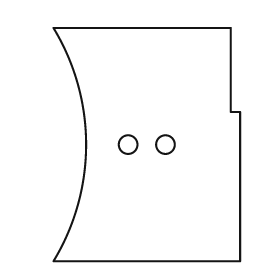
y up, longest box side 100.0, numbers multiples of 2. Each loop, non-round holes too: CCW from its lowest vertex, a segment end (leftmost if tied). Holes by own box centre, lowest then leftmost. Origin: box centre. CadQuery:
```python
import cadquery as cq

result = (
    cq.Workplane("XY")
    .moveTo(-40.0, -50.0)
    .lineTo(40.0, -50.0)
    .lineTo(40.0, 14.0)
    .lineTo(36.0, 14.0)
    .lineTo(36.0, 50.0)
    .lineTo(-40.0, 50.0)
    .threePointArc((-26.0, 0.0), (-40.0, -50.0))
    .close()
    .moveTo(-8.0, 0.0)
    .circle(4.0)
    .moveTo(8.0, 0.0)
    .circle(4.0)
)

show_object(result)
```